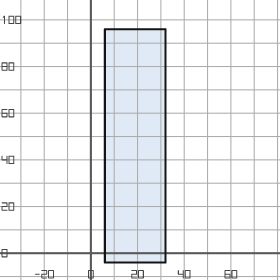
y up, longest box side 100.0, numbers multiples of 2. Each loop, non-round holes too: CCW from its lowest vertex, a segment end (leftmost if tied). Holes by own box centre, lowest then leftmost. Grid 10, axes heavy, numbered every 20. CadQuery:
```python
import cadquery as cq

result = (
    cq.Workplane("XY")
    .moveTo(6.0, -4.0)
    .lineTo(32.0, -4.0)
    .lineTo(32.0, 96.0)
    .lineTo(6.0, 96.0)
    .close()
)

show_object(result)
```